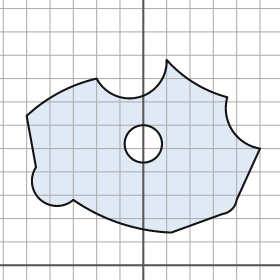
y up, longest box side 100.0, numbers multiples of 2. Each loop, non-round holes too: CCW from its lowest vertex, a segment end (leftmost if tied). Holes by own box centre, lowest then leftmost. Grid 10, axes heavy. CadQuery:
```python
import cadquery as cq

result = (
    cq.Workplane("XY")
    .moveTo(12.0, 14.0)
    .lineTo(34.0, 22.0)
    .threePointArc((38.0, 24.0), (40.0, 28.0))
    .lineTo(50.0, 50.0)
    .threePointArc((38.0, 58.0), (36.0, 72.0))
    .threePointArc((22.0, 78.0), (10.0, 88.0))
    .threePointArc((-2.0, 72.0), (-20.0, 80.0))
    .threePointArc((-36.0, 74.0), (-50.0, 64.0))
    .lineTo(-46.0, 42.0)
    .threePointArc((-44.0, 28.0), (-30.0, 28.0))
    .threePointArc((-10.0, 18.0), (12.0, 14.0))
    .close()
    .moveTo(0.0, 52.0)
    .circle(8.0)
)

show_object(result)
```